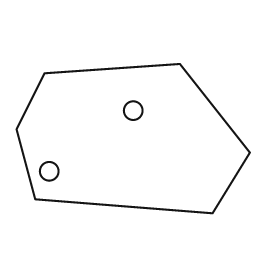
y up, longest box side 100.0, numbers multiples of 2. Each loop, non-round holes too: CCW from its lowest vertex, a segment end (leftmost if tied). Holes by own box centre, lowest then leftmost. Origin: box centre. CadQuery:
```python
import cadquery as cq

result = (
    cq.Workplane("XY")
    .moveTo(34.0, -32.0)
    .lineTo(50.0, -6.0)
    .lineTo(20.0, 32.0)
    .lineTo(-38.0, 28.0)
    .lineTo(-50.0, 4.0)
    .lineTo(-42.0, -26.0)
    .close()
    .moveTo(-36.0, -14.0)
    .circle(4.0)
    .moveTo(0.0, 12.0)
    .circle(4.0)
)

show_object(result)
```